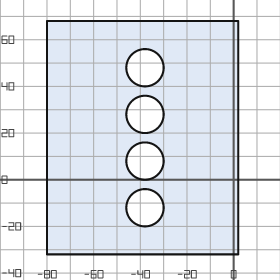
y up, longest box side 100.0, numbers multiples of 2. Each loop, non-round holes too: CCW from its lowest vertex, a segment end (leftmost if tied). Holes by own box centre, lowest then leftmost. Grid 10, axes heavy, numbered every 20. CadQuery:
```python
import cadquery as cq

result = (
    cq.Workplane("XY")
    .moveTo(-80.0, -32.0)
    .lineTo(2.0, -32.0)
    .lineTo(2.0, 68.0)
    .lineTo(-80.0, 68.0)
    .close()
    .moveTo(-38.0, -12.0)
    .circle(8.0)
    .moveTo(-38.0, 8.0)
    .circle(8.0)
    .moveTo(-38.0, 28.0)
    .circle(8.0)
    .moveTo(-38.0, 48.0)
    .circle(8.0)
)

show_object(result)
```